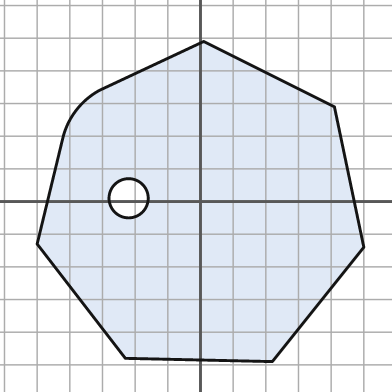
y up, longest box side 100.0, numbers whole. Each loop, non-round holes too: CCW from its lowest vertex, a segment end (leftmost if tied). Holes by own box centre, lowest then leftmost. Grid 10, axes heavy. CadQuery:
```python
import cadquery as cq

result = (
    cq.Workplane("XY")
    .moveTo(22.0, -49.0)
    .lineTo(50.0, -14.0)
    .lineTo(41.0, 29.0)
    .lineTo(1.0, 49.0)
    .lineTo(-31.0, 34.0)
    .threePointArc((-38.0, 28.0), (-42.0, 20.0))
    .lineTo(-50.0, -13.0)
    .lineTo(-23.0, -48.0)
    .close()
    .moveTo(-22.0, 1.0)
    .circle(6.0)
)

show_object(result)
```